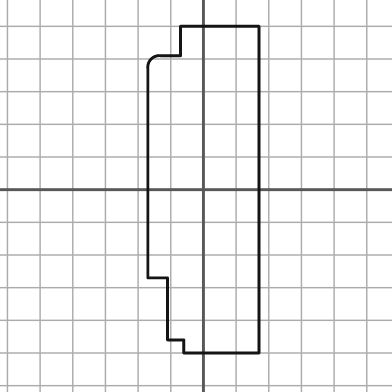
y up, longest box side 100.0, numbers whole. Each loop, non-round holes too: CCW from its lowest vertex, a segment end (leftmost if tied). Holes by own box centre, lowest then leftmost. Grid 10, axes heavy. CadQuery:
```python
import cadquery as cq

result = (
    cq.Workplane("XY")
    .moveTo(-6.0, -50.0)
    .lineTo(17.0, -50.0)
    .lineTo(17.0, 50.0)
    .lineTo(-7.0, 50.0)
    .lineTo(-7.0, 41.0)
    .lineTo(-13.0, 41.0)
    .threePointArc((-16.0, 40.0), (-17.0, 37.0))
    .lineTo(-17.0, -27.0)
    .lineTo(-11.0, -27.0)
    .lineTo(-11.0, -46.0)
    .lineTo(-6.0, -46.0)
    .close()
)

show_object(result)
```